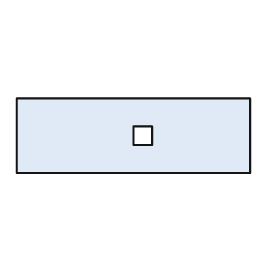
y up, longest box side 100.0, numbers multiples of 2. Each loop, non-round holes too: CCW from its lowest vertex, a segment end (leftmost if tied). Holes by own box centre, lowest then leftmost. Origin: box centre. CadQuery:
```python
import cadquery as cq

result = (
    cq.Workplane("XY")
    .moveTo(-50.0, -16.0)
    .lineTo(50.0, -16.0)
    .lineTo(50.0, 16.0)
    .lineTo(-50.0, 16.0)
    .close()
    .moveTo(0.0, -4.0)
    .lineTo(8.0, -4.0)
    .lineTo(8.0, 4.0)
    .lineTo(0.0, 4.0)
    .close()
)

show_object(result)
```